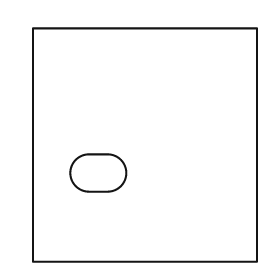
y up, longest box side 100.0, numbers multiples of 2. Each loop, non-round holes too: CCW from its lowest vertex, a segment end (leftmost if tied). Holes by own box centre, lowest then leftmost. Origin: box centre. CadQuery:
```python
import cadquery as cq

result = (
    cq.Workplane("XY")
    .moveTo(-48.0, -50.0)
    .lineTo(48.0, -50.0)
    .lineTo(48.0, 50.0)
    .lineTo(-48.0, 50.0)
    .close()
    .moveTo(-24.0, -20.0)
    .lineTo(-16.0, -20.0)
    .threePointArc((-8.0, -12.0), (-16.0, -4.0))
    .lineTo(-24.0, -4.0)
    .threePointArc((-32.0, -12.0), (-24.0, -20.0))
    .close()
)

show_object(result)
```